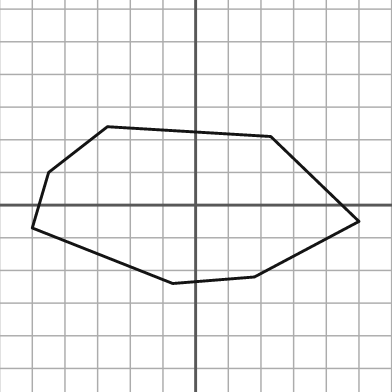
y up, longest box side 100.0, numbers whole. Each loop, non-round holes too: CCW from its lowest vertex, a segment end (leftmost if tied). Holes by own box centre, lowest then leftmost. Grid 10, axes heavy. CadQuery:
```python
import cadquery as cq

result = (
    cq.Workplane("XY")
    .moveTo(-7.0, -24.0)
    .lineTo(18.0, -22.0)
    .lineTo(50.0, -5.0)
    .lineTo(23.0, 21.0)
    .lineTo(-27.0, 24.0)
    .lineTo(-45.0, 10.0)
    .lineTo(-50.0, -7.0)
    .close()
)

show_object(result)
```